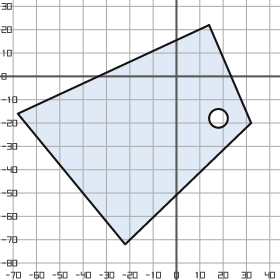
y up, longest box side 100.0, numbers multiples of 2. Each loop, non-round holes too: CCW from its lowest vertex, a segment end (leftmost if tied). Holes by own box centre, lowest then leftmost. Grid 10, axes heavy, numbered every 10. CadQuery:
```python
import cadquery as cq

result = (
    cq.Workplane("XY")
    .moveTo(-22.0, -72.0)
    .lineTo(32.0, -20.0)
    .lineTo(14.0, 22.0)
    .lineTo(-68.0, -16.0)
    .close()
    .moveTo(18.0, -18.0)
    .circle(4.0)
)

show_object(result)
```